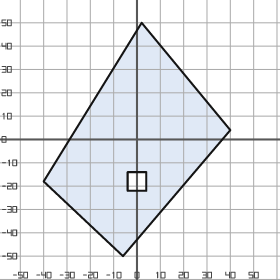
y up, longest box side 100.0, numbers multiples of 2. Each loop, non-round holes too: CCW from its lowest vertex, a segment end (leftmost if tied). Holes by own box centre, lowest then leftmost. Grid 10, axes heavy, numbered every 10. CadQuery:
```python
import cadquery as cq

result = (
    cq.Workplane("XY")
    .moveTo(-6.0, -50.0)
    .lineTo(40.0, 4.0)
    .lineTo(2.0, 50.0)
    .lineTo(-40.0, -18.0)
    .close()
    .moveTo(-4.0, -22.0)
    .lineTo(4.0, -22.0)
    .lineTo(4.0, -14.0)
    .lineTo(-4.0, -14.0)
    .close()
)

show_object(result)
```